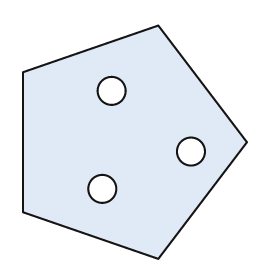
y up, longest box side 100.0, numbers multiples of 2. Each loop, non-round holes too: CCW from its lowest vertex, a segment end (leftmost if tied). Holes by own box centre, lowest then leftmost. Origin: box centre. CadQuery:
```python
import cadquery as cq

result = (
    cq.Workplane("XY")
    .moveTo(10.0, -50.0)
    .lineTo(48.0, 0.0)
    .lineTo(10.0, 50.0)
    .lineTo(-48.0, 30.0)
    .lineTo(-48.0, -30.0)
    .close()
    .moveTo(-14.0, -20.0)
    .circle(6.0)
    .moveTo(24.0, -4.0)
    .circle(6.0)
    .moveTo(-10.0, 22.0)
    .circle(6.0)
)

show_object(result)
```